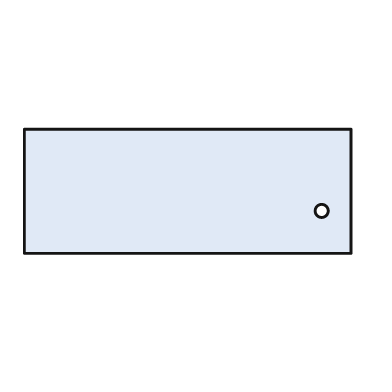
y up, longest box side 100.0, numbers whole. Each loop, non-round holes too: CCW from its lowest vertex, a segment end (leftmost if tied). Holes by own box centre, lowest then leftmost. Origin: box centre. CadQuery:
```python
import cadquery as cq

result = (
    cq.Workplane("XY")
    .moveTo(-50.0, -19.0)
    .lineTo(50.0, -19.0)
    .lineTo(50.0, 19.0)
    .lineTo(-50.0, 19.0)
    .close()
    .moveTo(41.0, -6.0)
    .circle(2.0)
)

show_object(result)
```